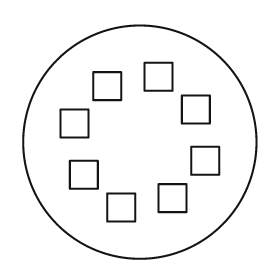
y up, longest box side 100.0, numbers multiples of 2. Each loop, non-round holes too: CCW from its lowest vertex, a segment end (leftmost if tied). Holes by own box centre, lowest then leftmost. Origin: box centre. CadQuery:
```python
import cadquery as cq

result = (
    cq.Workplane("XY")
    .moveTo(0.0, 0.0)
    .circle(50.0)
    .moveTo(-14.0, -34.0)
    .lineTo(-2.0, -34.0)
    .lineTo(-2.0, -22.0)
    .lineTo(-14.0, -22.0)
    .close()
    .moveTo(8.0, -30.0)
    .lineTo(20.0, -30.0)
    .lineTo(20.0, -18.0)
    .lineTo(8.0, -18.0)
    .close()
    .moveTo(-30.0, -20.0)
    .lineTo(-18.0, -20.0)
    .lineTo(-18.0, -8.0)
    .lineTo(-30.0, -8.0)
    .close()
    .moveTo(22.0, -14.0)
    .lineTo(34.0, -14.0)
    .lineTo(34.0, -2.0)
    .lineTo(22.0, -2.0)
    .close()
    .moveTo(-34.0, 2.0)
    .lineTo(-22.0, 2.0)
    .lineTo(-22.0, 14.0)
    .lineTo(-34.0, 14.0)
    .close()
    .moveTo(18.0, 8.0)
    .lineTo(30.0, 8.0)
    .lineTo(30.0, 20.0)
    .lineTo(18.0, 20.0)
    .close()
    .moveTo(-20.0, 18.0)
    .lineTo(-8.0, 18.0)
    .lineTo(-8.0, 30.0)
    .lineTo(-20.0, 30.0)
    .close()
    .moveTo(2.0, 22.0)
    .lineTo(14.0, 22.0)
    .lineTo(14.0, 34.0)
    .lineTo(2.0, 34.0)
    .close()
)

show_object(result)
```